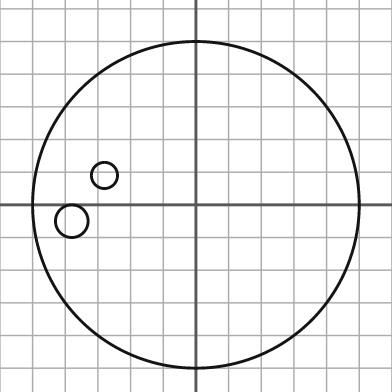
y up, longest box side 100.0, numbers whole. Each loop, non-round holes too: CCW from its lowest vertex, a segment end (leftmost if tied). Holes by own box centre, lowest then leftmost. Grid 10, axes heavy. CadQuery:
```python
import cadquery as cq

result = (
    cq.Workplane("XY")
    .moveTo(0.0, 0.0)
    .circle(50.0)
    .moveTo(-38.0, -5.0)
    .circle(5.0)
    .moveTo(-28.0, 9.0)
    .circle(4.0)
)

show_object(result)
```